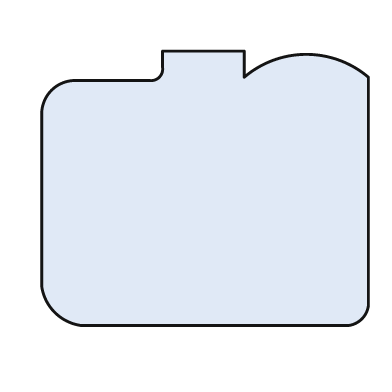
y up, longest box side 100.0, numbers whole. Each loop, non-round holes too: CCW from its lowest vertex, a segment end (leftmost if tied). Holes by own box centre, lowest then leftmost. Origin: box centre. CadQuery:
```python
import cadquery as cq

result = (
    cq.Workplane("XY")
    .moveTo(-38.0, -42.0)
    .lineTo(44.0, -42.0)
    .threePointArc((48.0, -40.0), (50.0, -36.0))
    .lineTo(50.0, 34.0)
    .threePointArc((31.0, 41.0), (12.0, 34.0))
    .lineTo(12.0, 42.0)
    .lineTo(-13.0, 42.0)
    .lineTo(-13.0, 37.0)
    .threePointArc((-14.0, 34.0), (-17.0, 33.0))
    .lineTo(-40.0, 33.0)
    .threePointArc((-47.0, 30.0), (-50.0, 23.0))
    .lineTo(-50.0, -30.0)
    .threePointArc((-46.0, -38.0), (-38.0, -42.0))
    .close()
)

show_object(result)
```